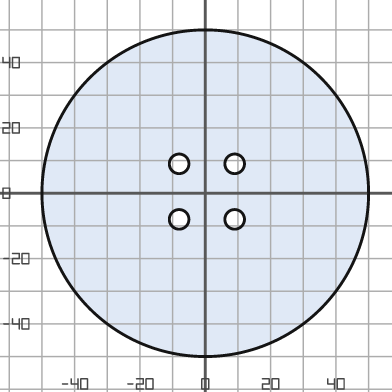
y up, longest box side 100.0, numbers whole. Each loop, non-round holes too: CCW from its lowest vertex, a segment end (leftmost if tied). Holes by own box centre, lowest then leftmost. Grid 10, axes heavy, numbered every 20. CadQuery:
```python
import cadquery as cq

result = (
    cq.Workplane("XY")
    .moveTo(0.0, 0.0)
    .circle(50.0)
    .moveTo(-8.0, -8.0)
    .circle(3.0)
    .moveTo(9.0, -8.0)
    .circle(3.0)
    .moveTo(-8.0, 9.0)
    .circle(3.0)
    .moveTo(9.0, 9.0)
    .circle(3.0)
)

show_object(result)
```